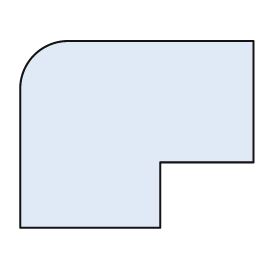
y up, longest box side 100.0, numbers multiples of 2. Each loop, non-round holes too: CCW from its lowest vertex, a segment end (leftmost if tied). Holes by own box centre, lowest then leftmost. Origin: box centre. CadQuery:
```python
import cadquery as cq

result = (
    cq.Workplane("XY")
    .moveTo(-50.0, -40.0)
    .lineTo(10.0, -40.0)
    .lineTo(10.0, -12.0)
    .lineTo(50.0, -12.0)
    .lineTo(50.0, 40.0)
    .lineTo(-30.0, 40.0)
    .threePointArc((-44.0, 34.0), (-50.0, 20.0))
    .close()
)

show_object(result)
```